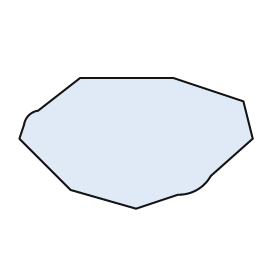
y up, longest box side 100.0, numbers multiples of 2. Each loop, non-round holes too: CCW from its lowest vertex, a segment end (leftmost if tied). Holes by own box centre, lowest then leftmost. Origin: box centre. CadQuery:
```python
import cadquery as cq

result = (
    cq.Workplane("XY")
    .moveTo(0.0, -28.0)
    .lineTo(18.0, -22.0)
    .threePointArc((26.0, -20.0), (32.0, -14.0))
    .lineTo(50.0, 2.0)
    .lineTo(46.0, 18.0)
    .lineTo(16.0, 28.0)
    .lineTo(-24.0, 28.0)
    .lineTo(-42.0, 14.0)
    .threePointArc((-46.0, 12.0), (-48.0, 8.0))
    .lineTo(-50.0, 2.0)
    .lineTo(-28.0, -20.0)
    .close()
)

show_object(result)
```